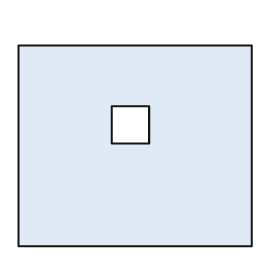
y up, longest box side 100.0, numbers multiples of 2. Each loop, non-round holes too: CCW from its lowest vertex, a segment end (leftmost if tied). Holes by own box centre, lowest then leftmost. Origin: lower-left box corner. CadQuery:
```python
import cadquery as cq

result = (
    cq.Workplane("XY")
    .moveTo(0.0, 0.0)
    .lineTo(100.0, 0.0)
    .lineTo(100.0, 86.0)
    .lineTo(0.0, 86.0)
    .close()
    .moveTo(40.0, 44.0)
    .lineTo(56.0, 44.0)
    .lineTo(56.0, 60.0)
    .lineTo(40.0, 60.0)
    .close()
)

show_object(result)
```